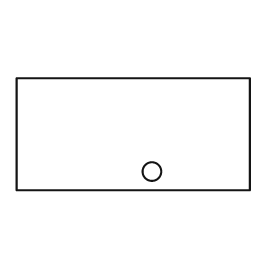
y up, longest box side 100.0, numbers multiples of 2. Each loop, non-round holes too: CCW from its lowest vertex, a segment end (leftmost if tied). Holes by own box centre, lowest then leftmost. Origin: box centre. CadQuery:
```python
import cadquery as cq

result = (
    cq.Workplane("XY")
    .moveTo(-50.0, -24.0)
    .lineTo(50.0, -24.0)
    .lineTo(50.0, 24.0)
    .lineTo(-50.0, 24.0)
    .close()
    .moveTo(8.0, -16.0)
    .circle(4.0)
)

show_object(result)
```